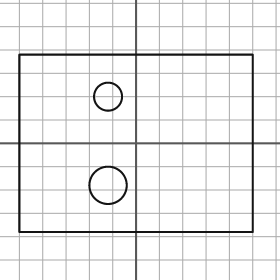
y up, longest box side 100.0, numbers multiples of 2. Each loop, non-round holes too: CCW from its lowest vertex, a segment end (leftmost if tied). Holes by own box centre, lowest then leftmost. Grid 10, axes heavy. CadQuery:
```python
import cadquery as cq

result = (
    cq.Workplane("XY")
    .moveTo(-50.0, -38.0)
    .lineTo(50.0, -38.0)
    .lineTo(50.0, 38.0)
    .lineTo(-50.0, 38.0)
    .close()
    .moveTo(-12.0, -18.0)
    .circle(8.0)
    .moveTo(-12.0, 20.0)
    .circle(6.0)
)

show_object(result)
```